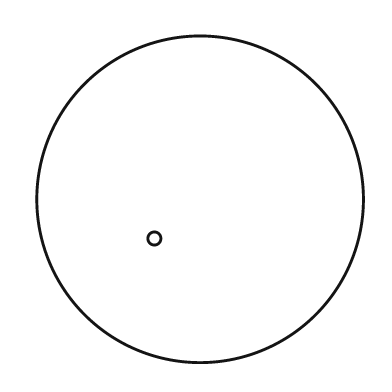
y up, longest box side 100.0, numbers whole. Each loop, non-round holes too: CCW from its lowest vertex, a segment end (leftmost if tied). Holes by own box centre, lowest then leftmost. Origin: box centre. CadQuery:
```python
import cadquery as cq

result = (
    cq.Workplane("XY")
    .moveTo(0.0, 0.0)
    .circle(50.0)
    .moveTo(-14.0, -12.0)
    .circle(2.0)
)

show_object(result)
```